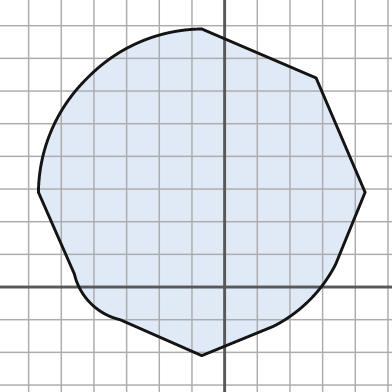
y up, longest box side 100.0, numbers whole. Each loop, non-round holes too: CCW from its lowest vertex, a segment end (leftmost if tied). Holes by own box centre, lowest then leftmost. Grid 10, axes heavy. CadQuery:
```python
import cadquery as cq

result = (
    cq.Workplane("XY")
    .moveTo(-7.0, -21.0)
    .lineTo(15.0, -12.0)
    .threePointArc((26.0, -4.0), (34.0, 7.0))
    .lineTo(43.0, 29.0)
    .lineTo(28.0, 64.0)
    .lineTo(-7.0, 79.0)
    .threePointArc((-26.0, 75.0), (-42.0, 64.0))
    .threePointArc((-53.0, 48.0), (-57.0, 29.0))
    .lineTo(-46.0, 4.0)
    .threePointArc((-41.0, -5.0), (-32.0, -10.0))
    .close()
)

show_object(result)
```